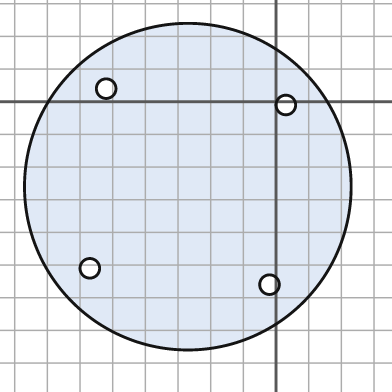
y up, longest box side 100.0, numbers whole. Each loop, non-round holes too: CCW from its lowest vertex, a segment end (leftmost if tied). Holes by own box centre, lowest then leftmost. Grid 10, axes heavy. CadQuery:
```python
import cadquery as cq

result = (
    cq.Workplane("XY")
    .moveTo(-27.0, -26.0)
    .circle(50.0)
    .moveTo(-2.0, -56.0)
    .circle(3.0)
    .moveTo(-57.0, -51.0)
    .circle(3.0)
    .moveTo(3.0, -1.0)
    .circle(3.0)
    .moveTo(-52.0, 4.0)
    .circle(3.0)
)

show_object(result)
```